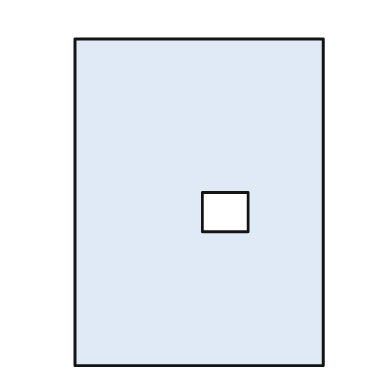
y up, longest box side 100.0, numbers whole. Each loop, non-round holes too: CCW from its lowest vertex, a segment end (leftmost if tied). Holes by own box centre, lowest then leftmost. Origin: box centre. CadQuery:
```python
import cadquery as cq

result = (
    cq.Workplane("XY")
    .moveTo(-38.0, -50.0)
    .lineTo(38.0, -50.0)
    .lineTo(38.0, 50.0)
    .lineTo(-38.0, 50.0)
    .close()
    .moveTo(1.0, -9.0)
    .lineTo(15.0, -9.0)
    .lineTo(15.0, 3.0)
    .lineTo(1.0, 3.0)
    .close()
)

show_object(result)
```